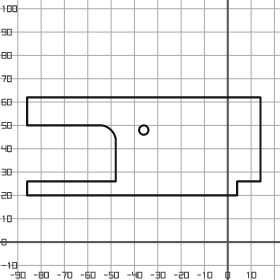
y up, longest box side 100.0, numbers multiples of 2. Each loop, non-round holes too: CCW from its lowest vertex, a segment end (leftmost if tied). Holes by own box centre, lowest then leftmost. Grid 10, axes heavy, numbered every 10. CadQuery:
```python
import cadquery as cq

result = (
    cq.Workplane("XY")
    .moveTo(-86.0, 20.0)
    .lineTo(4.0, 20.0)
    .lineTo(4.0, 26.0)
    .lineTo(14.0, 26.0)
    .lineTo(14.0, 62.0)
    .lineTo(-86.0, 62.0)
    .lineTo(-86.0, 50.0)
    .lineTo(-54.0, 50.0)
    .threePointArc((-50.0, 48.0), (-48.0, 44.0))
    .lineTo(-48.0, 26.0)
    .lineTo(-86.0, 26.0)
    .close()
    .moveTo(-36.0, 48.0)
    .circle(2.0)
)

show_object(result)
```